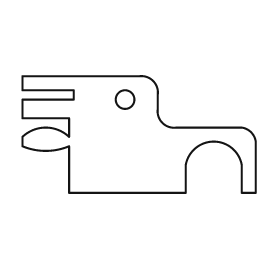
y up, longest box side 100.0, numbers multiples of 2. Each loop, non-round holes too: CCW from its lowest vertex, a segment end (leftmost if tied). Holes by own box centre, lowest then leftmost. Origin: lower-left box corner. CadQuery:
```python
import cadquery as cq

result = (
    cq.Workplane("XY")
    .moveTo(20.0, 0.0)
    .lineTo(70.0, 0.0)
    .lineTo(70.0, 12.0)
    .threePointArc((82.0, 22.0), (94.0, 12.0))
    .lineTo(94.0, 0.0)
    .lineTo(100.0, 0.0)
    .lineTo(100.0, 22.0)
    .threePointArc((98.0, 26.0), (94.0, 28.0))
    .lineTo(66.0, 28.0)
    .threePointArc((60.0, 30.0), (58.0, 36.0))
    .lineTo(58.0, 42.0)
    .threePointArc((56.0, 48.0), (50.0, 50.0))
    .lineTo(0.0, 50.0)
    .lineTo(0.0, 44.0)
    .lineTo(22.0, 44.0)
    .lineTo(22.0, 40.0)
    .lineTo(0.0, 40.0)
    .lineTo(0.0, 32.0)
    .lineTo(20.0, 32.0)
    .lineTo(20.0, 24.0)
    .threePointArc((10.0, 28.0), (0.0, 24.0))
    .lineTo(0.0, 20.0)
    .threePointArc((10.0, 18.0), (20.0, 20.0))
    .close()
    .moveTo(44.0, 40.0)
    .circle(4.0)
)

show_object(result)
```